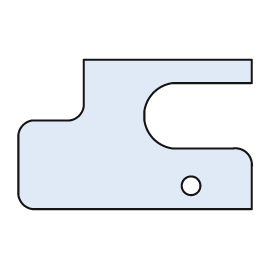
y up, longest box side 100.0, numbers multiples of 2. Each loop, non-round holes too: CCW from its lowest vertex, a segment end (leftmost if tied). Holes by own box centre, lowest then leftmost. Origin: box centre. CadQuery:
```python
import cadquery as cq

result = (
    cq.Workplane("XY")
    .moveTo(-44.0, -32.0)
    .lineTo(50.0, -32.0)
    .lineTo(50.0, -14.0)
    .threePointArc((48.0, -8.0), (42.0, -6.0))
    .lineTo(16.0, -6.0)
    .threePointArc((8.0, -2.0), (4.0, 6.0))
    .lineTo(4.0, 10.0)
    .threePointArc((8.0, 18.0), (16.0, 22.0))
    .lineTo(50.0, 22.0)
    .lineTo(50.0, 32.0)
    .lineTo(-22.0, 32.0)
    .lineTo(-22.0, 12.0)
    .threePointArc((-24.0, 8.0), (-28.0, 6.0))
    .lineTo(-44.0, 6.0)
    .threePointArc((-48.0, 4.0), (-50.0, 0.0))
    .lineTo(-50.0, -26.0)
    .threePointArc((-48.0, -30.0), (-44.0, -32.0))
    .close()
    .moveTo(24.0, -22.0)
    .circle(4.0)
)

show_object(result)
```